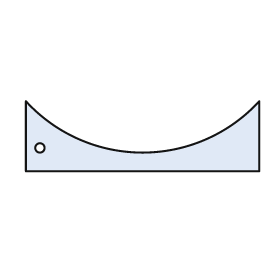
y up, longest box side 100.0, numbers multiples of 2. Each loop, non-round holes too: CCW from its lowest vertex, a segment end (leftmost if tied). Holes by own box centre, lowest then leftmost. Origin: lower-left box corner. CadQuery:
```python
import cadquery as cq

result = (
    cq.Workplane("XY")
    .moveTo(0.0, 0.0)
    .lineTo(100.0, 0.0)
    .lineTo(100.0, 30.0)
    .threePointArc((50.0, 8.0), (0.0, 30.0))
    .close()
    .moveTo(6.0, 10.0)
    .circle(2.0)
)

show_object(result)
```